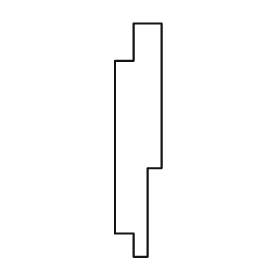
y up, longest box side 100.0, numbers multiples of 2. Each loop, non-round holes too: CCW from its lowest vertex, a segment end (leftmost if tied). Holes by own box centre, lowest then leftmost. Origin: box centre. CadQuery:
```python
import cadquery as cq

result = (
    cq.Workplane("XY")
    .moveTo(-2.0, -50.0)
    .lineTo(4.0, -50.0)
    .lineTo(4.0, -12.0)
    .lineTo(10.0, -12.0)
    .lineTo(10.0, 50.0)
    .lineTo(-2.0, 50.0)
    .lineTo(-2.0, 34.0)
    .lineTo(-10.0, 34.0)
    .lineTo(-10.0, -40.0)
    .lineTo(-2.0, -40.0)
    .close()
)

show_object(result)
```